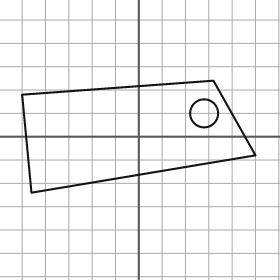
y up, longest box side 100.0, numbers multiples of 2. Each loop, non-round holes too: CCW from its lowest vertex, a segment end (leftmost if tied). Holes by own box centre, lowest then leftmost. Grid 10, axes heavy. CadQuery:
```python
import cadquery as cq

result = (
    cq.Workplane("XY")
    .moveTo(-46.0, -24.0)
    .lineTo(50.0, -8.0)
    .lineTo(32.0, 24.0)
    .lineTo(-50.0, 18.0)
    .close()
    .moveTo(28.0, 10.0)
    .circle(6.0)
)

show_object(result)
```